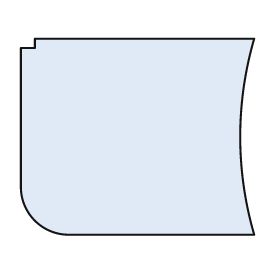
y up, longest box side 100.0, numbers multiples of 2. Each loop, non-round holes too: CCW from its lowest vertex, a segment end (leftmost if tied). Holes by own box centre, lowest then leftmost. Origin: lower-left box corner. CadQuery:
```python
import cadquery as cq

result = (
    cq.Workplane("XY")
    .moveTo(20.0, 0.0)
    .lineTo(100.0, 0.0)
    .threePointArc((94.0, 42.0), (100.0, 84.0))
    .lineTo(6.0, 84.0)
    .lineTo(6.0, 80.0)
    .lineTo(0.0, 80.0)
    .lineTo(0.0, 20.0)
    .threePointArc((6.0, 6.0), (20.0, 0.0))
    .close()
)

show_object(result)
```